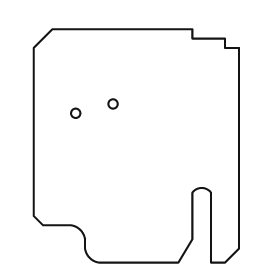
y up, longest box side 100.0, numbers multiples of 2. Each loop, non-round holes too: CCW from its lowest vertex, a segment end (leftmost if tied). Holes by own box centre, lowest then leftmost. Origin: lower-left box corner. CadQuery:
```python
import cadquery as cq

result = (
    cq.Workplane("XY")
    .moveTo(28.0, 0.0)
    .lineTo(62.0, 0.0)
    .lineTo(68.0, 10.0)
    .lineTo(68.0, 30.0)
    .threePointArc((72.0, 32.0), (76.0, 30.0))
    .lineTo(76.0, 0.0)
    .lineTo(82.0, 0.0)
    .lineTo(88.0, 6.0)
    .lineTo(88.0, 92.0)
    .lineTo(82.0, 92.0)
    .lineTo(82.0, 96.0)
    .lineTo(68.0, 96.0)
    .lineTo(68.0, 100.0)
    .lineTo(8.0, 100.0)
    .lineTo(0.0, 92.0)
    .lineTo(0.0, 20.0)
    .lineTo(4.0, 16.0)
    .lineTo(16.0, 16.0)
    .threePointArc((20.0, 14.0), (22.0, 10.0))
    .lineTo(22.0, 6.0)
    .threePointArc((24.0, 2.0), (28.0, 0.0))
    .close()
    .moveTo(18.0, 64.0)
    .circle(2.0)
    .moveTo(34.0, 68.0)
    .circle(2.0)
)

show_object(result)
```